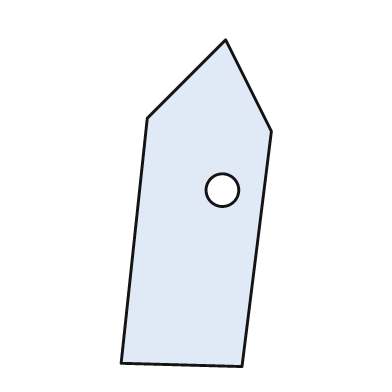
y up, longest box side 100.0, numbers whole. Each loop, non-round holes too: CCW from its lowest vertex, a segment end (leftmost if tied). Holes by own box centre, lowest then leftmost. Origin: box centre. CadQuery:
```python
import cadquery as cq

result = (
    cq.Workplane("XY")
    .moveTo(14.0, -50.0)
    .lineTo(23.0, 22.0)
    .lineTo(9.0, 50.0)
    .lineTo(-15.0, 26.0)
    .lineTo(-23.0, -49.0)
    .close()
    .moveTo(8.0, 4.0)
    .circle(5.0)
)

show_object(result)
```